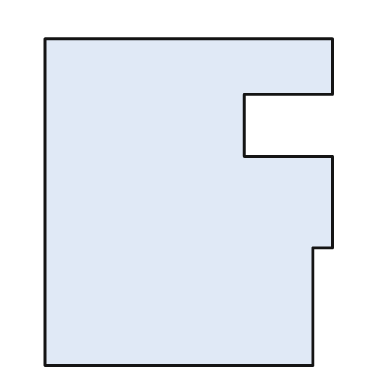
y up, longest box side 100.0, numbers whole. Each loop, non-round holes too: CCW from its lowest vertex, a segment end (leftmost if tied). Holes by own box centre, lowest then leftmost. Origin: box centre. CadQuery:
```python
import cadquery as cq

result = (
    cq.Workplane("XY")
    .moveTo(-44.0, -50.0)
    .lineTo(38.0, -50.0)
    .lineTo(38.0, -14.0)
    .lineTo(44.0, -14.0)
    .lineTo(44.0, 14.0)
    .lineTo(17.0, 14.0)
    .lineTo(17.0, 33.0)
    .lineTo(44.0, 33.0)
    .lineTo(44.0, 50.0)
    .lineTo(-44.0, 50.0)
    .close()
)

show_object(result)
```